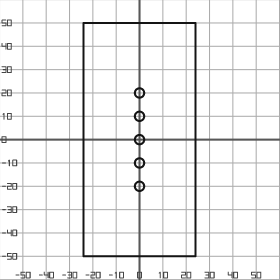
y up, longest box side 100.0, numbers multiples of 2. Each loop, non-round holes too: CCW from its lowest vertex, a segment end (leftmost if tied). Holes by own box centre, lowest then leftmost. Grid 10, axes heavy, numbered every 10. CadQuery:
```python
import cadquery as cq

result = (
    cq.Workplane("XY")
    .moveTo(-24.0, -50.0)
    .lineTo(24.0, -50.0)
    .lineTo(24.0, 50.0)
    .lineTo(-24.0, 50.0)
    .close()
    .moveTo(0.0, -20.0)
    .circle(2.0)
    .moveTo(0.0, -10.0)
    .circle(2.0)
    .moveTo(0.0, 0.0)
    .circle(2.0)
    .moveTo(0.0, 10.0)
    .circle(2.0)
    .moveTo(0.0, 20.0)
    .circle(2.0)
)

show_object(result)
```